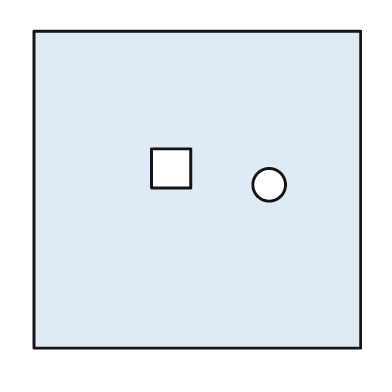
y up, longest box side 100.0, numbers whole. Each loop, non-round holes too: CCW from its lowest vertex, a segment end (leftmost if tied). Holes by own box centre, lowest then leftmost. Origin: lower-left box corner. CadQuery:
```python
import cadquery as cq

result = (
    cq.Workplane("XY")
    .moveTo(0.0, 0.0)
    .lineTo(100.0, 0.0)
    .lineTo(100.0, 97.0)
    .lineTo(0.0, 97.0)
    .close()
    .moveTo(72.0, 50.0)
    .circle(5.0)
    .moveTo(36.0, 49.0)
    .lineTo(48.0, 49.0)
    .lineTo(48.0, 61.0)
    .lineTo(36.0, 61.0)
    .close()
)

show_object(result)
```